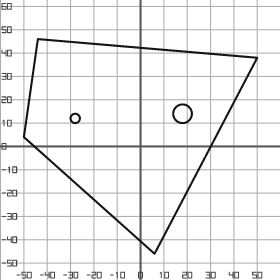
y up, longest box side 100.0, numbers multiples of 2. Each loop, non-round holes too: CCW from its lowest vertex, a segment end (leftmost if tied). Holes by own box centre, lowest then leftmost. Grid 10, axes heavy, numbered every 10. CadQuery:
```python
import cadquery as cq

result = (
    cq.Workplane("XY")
    .moveTo(6.0, -46.0)
    .lineTo(50.0, 38.0)
    .lineTo(-44.0, 46.0)
    .lineTo(-50.0, 4.0)
    .close()
    .moveTo(-28.0, 12.0)
    .circle(2.0)
    .moveTo(18.0, 14.0)
    .circle(4.0)
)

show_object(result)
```